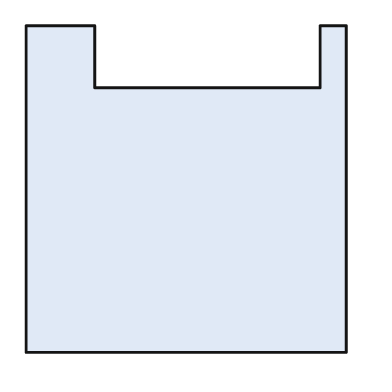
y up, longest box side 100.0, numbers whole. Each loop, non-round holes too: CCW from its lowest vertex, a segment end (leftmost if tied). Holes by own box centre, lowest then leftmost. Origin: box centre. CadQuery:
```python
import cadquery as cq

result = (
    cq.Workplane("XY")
    .moveTo(-49.0, -50.0)
    .lineTo(49.0, -50.0)
    .lineTo(49.0, 50.0)
    .lineTo(41.0, 50.0)
    .lineTo(41.0, 31.0)
    .lineTo(-28.0, 31.0)
    .lineTo(-28.0, 50.0)
    .lineTo(-49.0, 50.0)
    .close()
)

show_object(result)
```